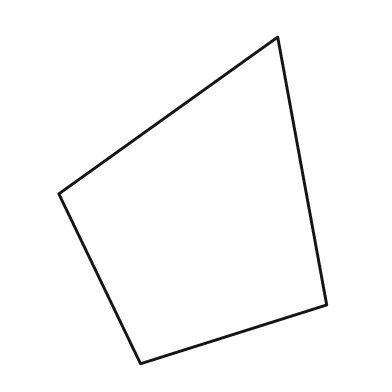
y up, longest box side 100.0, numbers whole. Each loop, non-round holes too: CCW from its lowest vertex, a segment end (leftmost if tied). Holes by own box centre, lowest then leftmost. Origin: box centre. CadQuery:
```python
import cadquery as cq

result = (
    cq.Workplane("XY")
    .moveTo(-16.0, -50.0)
    .lineTo(41.0, -32.0)
    .lineTo(26.0, 50.0)
    .lineTo(-41.0, 2.0)
    .close()
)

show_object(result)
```